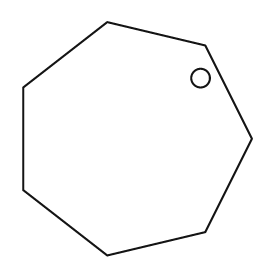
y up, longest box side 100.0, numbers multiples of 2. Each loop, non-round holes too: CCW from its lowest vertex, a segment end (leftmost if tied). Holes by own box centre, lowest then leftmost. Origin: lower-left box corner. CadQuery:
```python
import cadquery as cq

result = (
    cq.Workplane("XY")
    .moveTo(36.0, 0.0)
    .lineTo(78.0, 10.0)
    .lineTo(98.0, 50.0)
    .lineTo(78.0, 90.0)
    .lineTo(36.0, 100.0)
    .lineTo(0.0, 72.0)
    .lineTo(0.0, 28.0)
    .close()
    .moveTo(76.0, 76.0)
    .circle(4.0)
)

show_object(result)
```